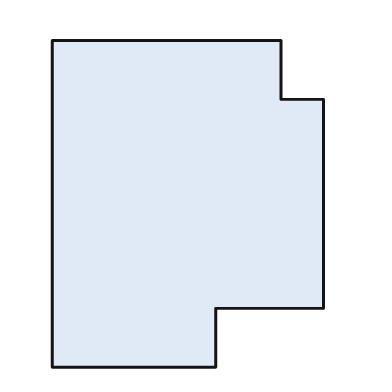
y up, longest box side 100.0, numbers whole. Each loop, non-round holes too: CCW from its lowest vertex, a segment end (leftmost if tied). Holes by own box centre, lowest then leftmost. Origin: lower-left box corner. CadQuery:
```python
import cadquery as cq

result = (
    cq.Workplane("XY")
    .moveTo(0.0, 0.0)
    .lineTo(50.0, 0.0)
    .lineTo(50.0, 18.0)
    .lineTo(83.0, 18.0)
    .lineTo(83.0, 82.0)
    .lineTo(70.0, 82.0)
    .lineTo(70.0, 100.0)
    .lineTo(0.0, 100.0)
    .close()
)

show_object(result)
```